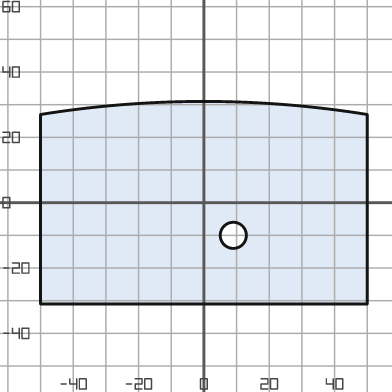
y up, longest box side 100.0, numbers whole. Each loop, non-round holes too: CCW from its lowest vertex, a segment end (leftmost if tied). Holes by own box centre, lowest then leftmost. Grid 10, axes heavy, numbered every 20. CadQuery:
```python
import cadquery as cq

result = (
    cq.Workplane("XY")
    .moveTo(-50.0, -31.0)
    .lineTo(50.0, -31.0)
    .lineTo(50.0, 27.0)
    .threePointArc((0.0, 31.0), (-50.0, 27.0))
    .close()
    .moveTo(9.0, -10.0)
    .circle(4.0)
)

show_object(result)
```